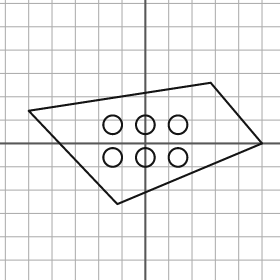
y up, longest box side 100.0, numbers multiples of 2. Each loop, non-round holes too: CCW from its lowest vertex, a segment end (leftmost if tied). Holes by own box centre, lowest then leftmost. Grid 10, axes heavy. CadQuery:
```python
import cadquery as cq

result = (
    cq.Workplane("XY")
    .moveTo(-12.0, -26.0)
    .lineTo(50.0, 0.0)
    .lineTo(28.0, 26.0)
    .lineTo(-50.0, 14.0)
    .close()
    .moveTo(-14.0, -6.0)
    .circle(4.0)
    .moveTo(0.0, -6.0)
    .circle(4.0)
    .moveTo(14.0, -6.0)
    .circle(4.0)
    .moveTo(-14.0, 8.0)
    .circle(4.0)
    .moveTo(0.0, 8.0)
    .circle(4.0)
    .moveTo(14.0, 8.0)
    .circle(4.0)
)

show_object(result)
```